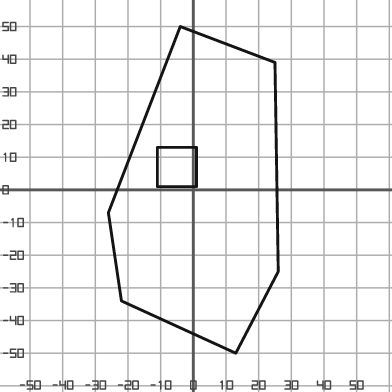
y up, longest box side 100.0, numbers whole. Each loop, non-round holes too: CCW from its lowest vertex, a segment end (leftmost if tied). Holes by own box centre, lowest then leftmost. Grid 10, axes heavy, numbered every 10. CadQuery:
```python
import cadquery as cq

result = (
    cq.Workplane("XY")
    .moveTo(13.0, -50.0)
    .lineTo(26.0, -25.0)
    .lineTo(25.0, 39.0)
    .lineTo(-4.0, 50.0)
    .lineTo(-26.0, -7.0)
    .lineTo(-22.0, -34.0)
    .close()
    .moveTo(-11.0, 1.0)
    .lineTo(1.0, 1.0)
    .lineTo(1.0, 13.0)
    .lineTo(-11.0, 13.0)
    .close()
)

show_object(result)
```